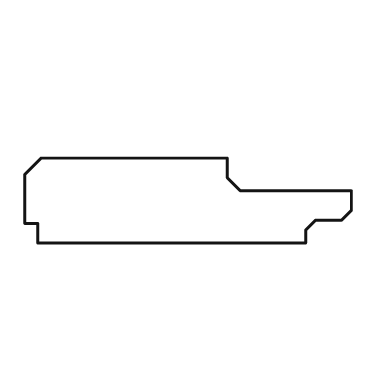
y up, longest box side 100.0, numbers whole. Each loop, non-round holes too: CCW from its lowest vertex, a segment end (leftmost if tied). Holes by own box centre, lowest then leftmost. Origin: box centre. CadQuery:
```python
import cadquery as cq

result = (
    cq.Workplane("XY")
    .moveTo(-46.0, -13.0)
    .lineTo(36.0, -13.0)
    .lineTo(36.0, -9.0)
    .lineTo(39.0, -6.0)
    .lineTo(47.0, -6.0)
    .lineTo(50.0, -3.0)
    .lineTo(50.0, 3.0)
    .lineTo(16.0, 3.0)
    .lineTo(12.0, 7.0)
    .lineTo(12.0, 13.0)
    .lineTo(-45.0, 13.0)
    .lineTo(-50.0, 8.0)
    .lineTo(-50.0, -7.0)
    .lineTo(-46.0, -7.0)
    .close()
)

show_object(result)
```